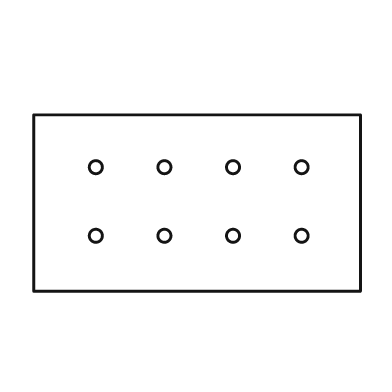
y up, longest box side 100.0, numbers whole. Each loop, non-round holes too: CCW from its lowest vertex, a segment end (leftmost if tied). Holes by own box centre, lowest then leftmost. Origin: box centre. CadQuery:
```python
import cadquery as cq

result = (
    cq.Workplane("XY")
    .moveTo(-50.0, -27.0)
    .lineTo(50.0, -27.0)
    .lineTo(50.0, 27.0)
    .lineTo(-50.0, 27.0)
    .close()
    .moveTo(-31.0, -10.0)
    .circle(2.0)
    .moveTo(-10.0, -10.0)
    .circle(2.0)
    .moveTo(11.0, -10.0)
    .circle(2.0)
    .moveTo(32.0, -10.0)
    .circle(2.0)
    .moveTo(-31.0, 11.0)
    .circle(2.0)
    .moveTo(-10.0, 11.0)
    .circle(2.0)
    .moveTo(11.0, 11.0)
    .circle(2.0)
    .moveTo(32.0, 11.0)
    .circle(2.0)
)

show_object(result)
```